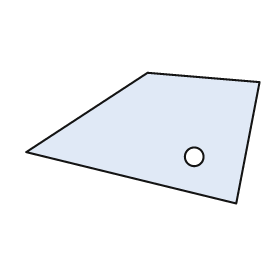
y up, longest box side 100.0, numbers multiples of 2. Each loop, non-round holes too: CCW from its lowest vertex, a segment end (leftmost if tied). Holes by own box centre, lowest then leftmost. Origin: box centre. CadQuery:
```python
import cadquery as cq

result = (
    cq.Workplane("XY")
    .moveTo(40.0, -28.0)
    .lineTo(50.0, 24.0)
    .lineTo(2.0, 28.0)
    .lineTo(-50.0, -6.0)
    .close()
    .moveTo(22.0, -8.0)
    .circle(4.0)
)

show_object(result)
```